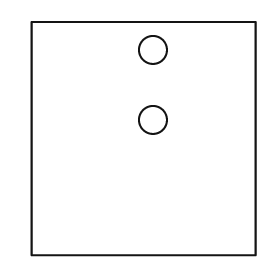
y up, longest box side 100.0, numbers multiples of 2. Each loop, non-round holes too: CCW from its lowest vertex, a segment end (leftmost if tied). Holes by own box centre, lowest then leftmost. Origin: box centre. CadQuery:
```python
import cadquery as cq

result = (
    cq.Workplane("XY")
    .moveTo(-48.0, -50.0)
    .lineTo(48.0, -50.0)
    .lineTo(48.0, 50.0)
    .lineTo(-48.0, 50.0)
    .close()
    .moveTo(4.0, 8.0)
    .circle(6.0)
    .moveTo(4.0, 38.0)
    .circle(6.0)
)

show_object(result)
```